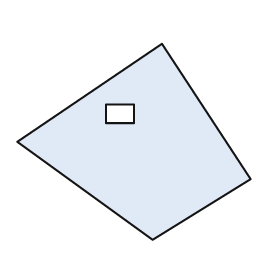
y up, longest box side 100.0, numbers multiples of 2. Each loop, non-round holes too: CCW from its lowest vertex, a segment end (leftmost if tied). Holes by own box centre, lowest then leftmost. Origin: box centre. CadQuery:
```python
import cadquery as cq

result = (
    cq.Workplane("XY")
    .moveTo(8.0, -42.0)
    .lineTo(50.0, -16.0)
    .lineTo(12.0, 42.0)
    .lineTo(-50.0, 0.0)
    .close()
    .moveTo(-12.0, 8.0)
    .lineTo(0.0, 8.0)
    .lineTo(0.0, 16.0)
    .lineTo(-12.0, 16.0)
    .close()
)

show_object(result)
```